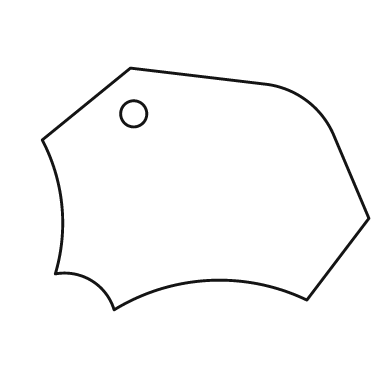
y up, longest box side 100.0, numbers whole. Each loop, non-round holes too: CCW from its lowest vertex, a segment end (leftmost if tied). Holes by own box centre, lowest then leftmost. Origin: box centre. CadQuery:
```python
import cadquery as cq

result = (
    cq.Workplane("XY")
    .moveTo(-28.0, -37.0)
    .threePointArc((1.0, -28.0), (31.0, -34.0))
    .lineTo(50.0, -9.0)
    .lineTo(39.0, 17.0)
    .threePointArc((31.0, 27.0), (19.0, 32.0))
    .lineTo(-23.0, 37.0)
    .lineTo(-50.0, 15.0)
    .threePointArc((-44.0, -5.0), (-46.0, -26.0))
    .threePointArc((-35.0, -28.0), (-28.0, -37.0))
    .close()
    .moveTo(-22.0, 23.0)
    .circle(4.0)
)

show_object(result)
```